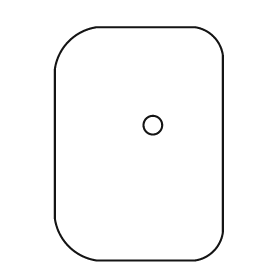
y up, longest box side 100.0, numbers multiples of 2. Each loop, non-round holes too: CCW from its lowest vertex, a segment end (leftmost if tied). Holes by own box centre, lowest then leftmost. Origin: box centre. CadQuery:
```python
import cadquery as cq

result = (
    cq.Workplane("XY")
    .moveTo(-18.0, -50.0)
    .lineTo(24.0, -50.0)
    .threePointArc((32.0, -46.0), (36.0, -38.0))
    .lineTo(36.0, 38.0)
    .threePointArc((32.0, 46.0), (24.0, 50.0))
    .lineTo(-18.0, 50.0)
    .threePointArc((-30.0, 44.0), (-36.0, 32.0))
    .lineTo(-36.0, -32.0)
    .threePointArc((-30.0, -44.0), (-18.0, -50.0))
    .close()
    .moveTo(6.0, 8.0)
    .circle(4.0)
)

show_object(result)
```